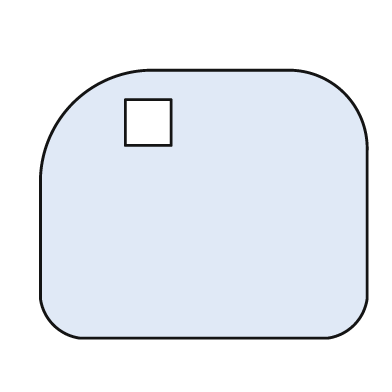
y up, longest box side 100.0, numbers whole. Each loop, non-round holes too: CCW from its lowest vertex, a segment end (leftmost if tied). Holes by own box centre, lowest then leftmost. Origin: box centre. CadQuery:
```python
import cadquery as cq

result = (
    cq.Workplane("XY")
    .moveTo(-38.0, -41.0)
    .lineTo(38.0, -41.0)
    .threePointArc((46.0, -37.0), (50.0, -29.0))
    .lineTo(50.0, 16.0)
    .threePointArc((43.0, 34.0), (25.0, 41.0))
    .lineTo(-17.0, 41.0)
    .threePointArc((-40.0, 31.0), (-50.0, 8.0))
    .lineTo(-50.0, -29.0)
    .threePointArc((-46.0, -37.0), (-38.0, -41.0))
    .close()
    .moveTo(-24.0, 18.0)
    .lineTo(-10.0, 18.0)
    .lineTo(-10.0, 32.0)
    .lineTo(-24.0, 32.0)
    .close()
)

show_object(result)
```